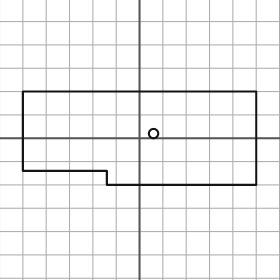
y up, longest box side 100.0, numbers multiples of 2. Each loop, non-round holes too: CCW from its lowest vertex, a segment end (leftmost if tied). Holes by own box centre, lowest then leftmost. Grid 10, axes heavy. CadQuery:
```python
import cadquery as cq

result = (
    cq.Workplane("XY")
    .moveTo(-14.0, -20.0)
    .lineTo(50.0, -20.0)
    .lineTo(50.0, 20.0)
    .lineTo(-50.0, 20.0)
    .lineTo(-50.0, -14.0)
    .lineTo(-14.0, -14.0)
    .close()
    .moveTo(6.0, 2.0)
    .circle(2.0)
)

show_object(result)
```